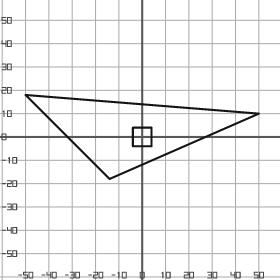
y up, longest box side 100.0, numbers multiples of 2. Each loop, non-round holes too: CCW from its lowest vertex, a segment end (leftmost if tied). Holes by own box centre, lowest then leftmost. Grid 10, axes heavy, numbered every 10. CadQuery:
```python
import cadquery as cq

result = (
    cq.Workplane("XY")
    .moveTo(-14.0, -18.0)
    .lineTo(50.0, 10.0)
    .lineTo(-50.0, 18.0)
    .close()
    .moveTo(-4.0, -4.0)
    .lineTo(4.0, -4.0)
    .lineTo(4.0, 4.0)
    .lineTo(-4.0, 4.0)
    .close()
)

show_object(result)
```